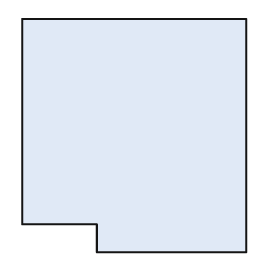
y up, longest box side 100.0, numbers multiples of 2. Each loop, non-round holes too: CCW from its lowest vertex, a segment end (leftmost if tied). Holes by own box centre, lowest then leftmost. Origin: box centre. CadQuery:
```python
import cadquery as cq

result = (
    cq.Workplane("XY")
    .moveTo(-16.0, -50.0)
    .lineTo(48.0, -50.0)
    .lineTo(48.0, 50.0)
    .lineTo(-48.0, 50.0)
    .lineTo(-48.0, -38.0)
    .lineTo(-16.0, -38.0)
    .close()
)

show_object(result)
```